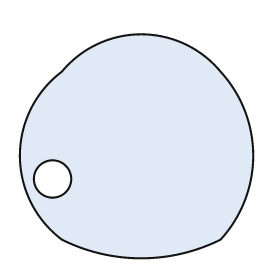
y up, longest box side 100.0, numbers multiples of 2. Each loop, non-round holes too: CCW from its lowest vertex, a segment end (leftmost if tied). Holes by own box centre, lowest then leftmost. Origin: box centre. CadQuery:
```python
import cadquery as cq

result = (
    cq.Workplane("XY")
    .moveTo(-32.0, -40.0)
    .threePointArc((2.0, -48.0), (36.0, -40.0))
    .threePointArc((50.0, -4.0), (36.0, 32.0))
    .threePointArc((2.0, 48.0), (-32.0, 32.0))
    .threePointArc((-50.0, -4.0), (-32.0, -40.0))
    .close()
    .moveTo(-36.0, -14.0)
    .circle(8.0)
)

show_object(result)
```